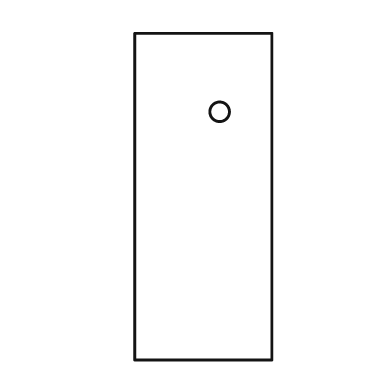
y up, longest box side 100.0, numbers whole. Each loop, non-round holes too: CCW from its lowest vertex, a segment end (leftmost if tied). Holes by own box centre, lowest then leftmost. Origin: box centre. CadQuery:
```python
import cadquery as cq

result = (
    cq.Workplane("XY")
    .moveTo(-21.0, -50.0)
    .lineTo(21.0, -50.0)
    .lineTo(21.0, 50.0)
    .lineTo(-21.0, 50.0)
    .close()
    .moveTo(5.0, 26.0)
    .circle(3.0)
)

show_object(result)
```